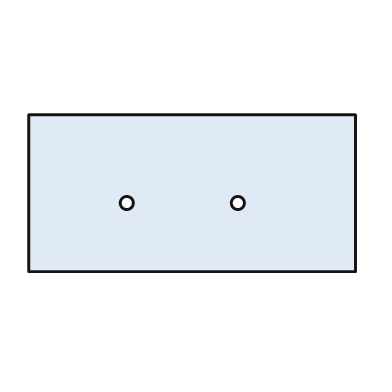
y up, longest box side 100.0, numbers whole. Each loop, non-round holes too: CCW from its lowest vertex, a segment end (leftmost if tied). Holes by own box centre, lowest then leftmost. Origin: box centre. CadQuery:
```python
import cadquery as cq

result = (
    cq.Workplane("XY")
    .moveTo(-50.0, -24.0)
    .lineTo(50.0, -24.0)
    .lineTo(50.0, 24.0)
    .lineTo(-50.0, 24.0)
    .close()
    .moveTo(-20.0, -3.0)
    .circle(2.0)
    .moveTo(14.0, -3.0)
    .circle(2.0)
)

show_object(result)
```